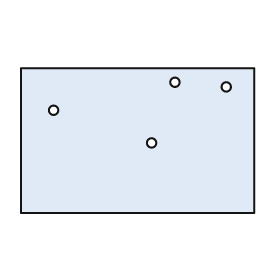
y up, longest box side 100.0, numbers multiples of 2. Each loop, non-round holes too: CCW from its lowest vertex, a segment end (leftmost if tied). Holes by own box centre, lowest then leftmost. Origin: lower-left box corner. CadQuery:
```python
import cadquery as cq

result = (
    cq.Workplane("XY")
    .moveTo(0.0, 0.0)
    .lineTo(100.0, 0.0)
    .lineTo(100.0, 62.0)
    .lineTo(0.0, 62.0)
    .close()
    .moveTo(56.0, 30.0)
    .circle(2.0)
    .moveTo(14.0, 44.0)
    .circle(2.0)
    .moveTo(88.0, 54.0)
    .circle(2.0)
    .moveTo(66.0, 56.0)
    .circle(2.0)
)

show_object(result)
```